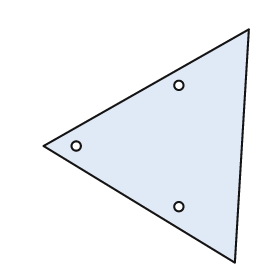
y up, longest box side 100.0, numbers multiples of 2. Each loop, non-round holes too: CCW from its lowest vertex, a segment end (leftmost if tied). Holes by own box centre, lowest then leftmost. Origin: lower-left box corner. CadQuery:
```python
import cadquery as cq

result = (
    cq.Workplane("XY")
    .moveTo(82.0, 0.0)
    .lineTo(88.0, 100.0)
    .lineTo(0.0, 50.0)
    .close()
    .moveTo(58.0, 24.0)
    .circle(2.0)
    .moveTo(14.0, 50.0)
    .circle(2.0)
    .moveTo(58.0, 76.0)
    .circle(2.0)
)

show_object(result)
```